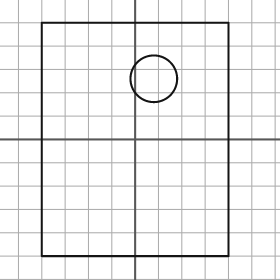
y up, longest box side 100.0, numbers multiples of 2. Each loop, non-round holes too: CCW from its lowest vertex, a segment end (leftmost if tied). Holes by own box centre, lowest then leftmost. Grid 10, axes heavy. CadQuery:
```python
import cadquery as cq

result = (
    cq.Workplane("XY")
    .moveTo(-40.0, -50.0)
    .lineTo(40.0, -50.0)
    .lineTo(40.0, 50.0)
    .lineTo(-40.0, 50.0)
    .close()
    .moveTo(8.0, 26.0)
    .circle(10.0)
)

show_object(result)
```